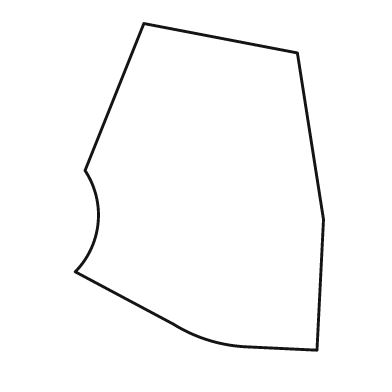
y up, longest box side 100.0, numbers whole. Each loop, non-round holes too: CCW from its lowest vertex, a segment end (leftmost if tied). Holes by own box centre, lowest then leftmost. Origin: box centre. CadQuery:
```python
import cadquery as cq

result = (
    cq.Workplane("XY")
    .moveTo(36.0, -50.0)
    .lineTo(38.0, -10.0)
    .lineTo(30.0, 41.0)
    .lineTo(-17.0, 50.0)
    .lineTo(-35.0, 5.0)
    .threePointArc((-31.0, -11.0), (-38.0, -26.0))
    .lineTo(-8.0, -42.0)
    .threePointArc((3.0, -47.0), (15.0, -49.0))
    .close()
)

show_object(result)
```